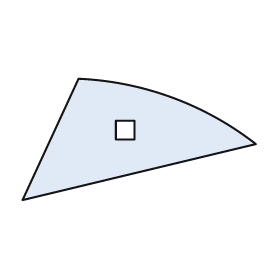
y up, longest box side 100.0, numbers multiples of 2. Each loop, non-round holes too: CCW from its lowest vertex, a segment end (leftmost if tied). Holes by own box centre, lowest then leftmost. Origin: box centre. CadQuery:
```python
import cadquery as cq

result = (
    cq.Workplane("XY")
    .moveTo(-50.0, -26.0)
    .lineTo(50.0, -2.0)
    .threePointArc((14.0, 18.0), (-26.0, 26.0))
    .close()
    .moveTo(-10.0, 0.0)
    .lineTo(-2.0, 0.0)
    .lineTo(-2.0, 8.0)
    .lineTo(-10.0, 8.0)
    .close()
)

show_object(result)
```